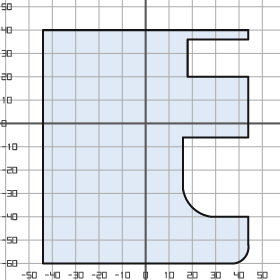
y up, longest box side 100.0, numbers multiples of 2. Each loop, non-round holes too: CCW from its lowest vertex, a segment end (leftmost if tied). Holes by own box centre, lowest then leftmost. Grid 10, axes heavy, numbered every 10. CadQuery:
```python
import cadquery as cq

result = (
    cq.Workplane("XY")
    .moveTo(-44.0, -60.0)
    .lineTo(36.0, -60.0)
    .threePointArc((42.0, -58.0), (44.0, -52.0))
    .lineTo(44.0, -40.0)
    .lineTo(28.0, -40.0)
    .threePointArc((20.0, -36.0), (16.0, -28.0))
    .lineTo(16.0, -6.0)
    .lineTo(44.0, -6.0)
    .lineTo(44.0, 20.0)
    .lineTo(18.0, 20.0)
    .lineTo(18.0, 36.0)
    .lineTo(44.0, 36.0)
    .lineTo(44.0, 40.0)
    .lineTo(-44.0, 40.0)
    .close()
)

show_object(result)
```